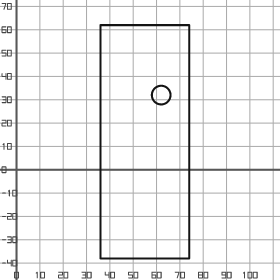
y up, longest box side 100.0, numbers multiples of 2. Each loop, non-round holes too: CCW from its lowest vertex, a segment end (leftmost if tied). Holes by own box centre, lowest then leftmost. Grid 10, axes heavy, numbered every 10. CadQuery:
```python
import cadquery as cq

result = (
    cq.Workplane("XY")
    .moveTo(36.0, -38.0)
    .lineTo(74.0, -38.0)
    .lineTo(74.0, 62.0)
    .lineTo(36.0, 62.0)
    .close()
    .moveTo(62.0, 32.0)
    .circle(4.0)
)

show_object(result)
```